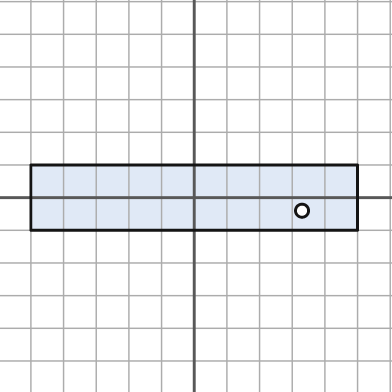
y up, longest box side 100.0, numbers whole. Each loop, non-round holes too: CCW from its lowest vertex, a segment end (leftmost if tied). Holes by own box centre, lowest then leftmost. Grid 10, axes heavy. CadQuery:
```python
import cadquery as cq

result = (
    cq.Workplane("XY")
    .moveTo(-50.0, -10.0)
    .lineTo(50.0, -10.0)
    .lineTo(50.0, 10.0)
    .lineTo(-50.0, 10.0)
    .close()
    .moveTo(33.0, -4.0)
    .circle(2.0)
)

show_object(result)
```